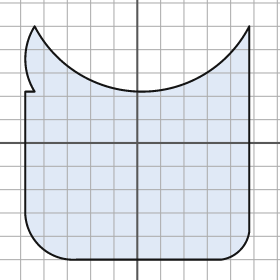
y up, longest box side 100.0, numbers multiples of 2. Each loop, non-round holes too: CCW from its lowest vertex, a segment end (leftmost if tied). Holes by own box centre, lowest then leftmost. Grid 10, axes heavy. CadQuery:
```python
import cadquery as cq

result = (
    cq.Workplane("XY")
    .moveTo(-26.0, -50.0)
    .lineTo(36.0, -50.0)
    .threePointArc((44.0, -46.0), (48.0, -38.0))
    .lineTo(48.0, 50.0)
    .threePointArc((2.0, 22.0), (-44.0, 50.0))
    .threePointArc((-48.0, 36.0), (-44.0, 22.0))
    .lineTo(-48.0, 22.0)
    .lineTo(-48.0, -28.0)
    .threePointArc((-42.0, -44.0), (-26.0, -50.0))
    .close()
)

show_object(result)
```